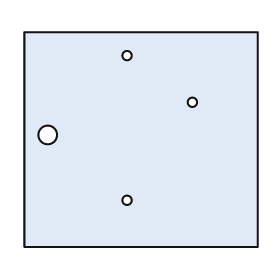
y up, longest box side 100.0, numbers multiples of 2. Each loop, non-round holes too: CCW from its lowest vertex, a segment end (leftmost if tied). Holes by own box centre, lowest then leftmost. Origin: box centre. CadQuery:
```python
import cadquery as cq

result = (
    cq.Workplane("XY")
    .moveTo(-50.0, -46.0)
    .lineTo(50.0, -46.0)
    .lineTo(50.0, 46.0)
    .lineTo(-50.0, 46.0)
    .close()
    .moveTo(-6.0, -26.0)
    .circle(2.0)
    .moveTo(-40.0, 2.0)
    .circle(4.0)
    .moveTo(22.0, 16.0)
    .circle(2.0)
    .moveTo(-6.0, 36.0)
    .circle(2.0)
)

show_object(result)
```